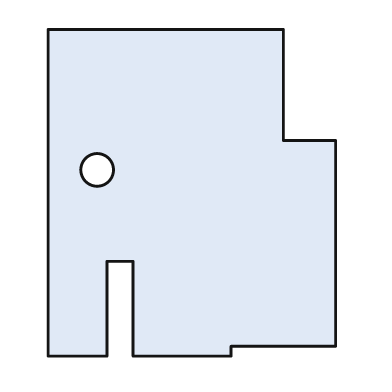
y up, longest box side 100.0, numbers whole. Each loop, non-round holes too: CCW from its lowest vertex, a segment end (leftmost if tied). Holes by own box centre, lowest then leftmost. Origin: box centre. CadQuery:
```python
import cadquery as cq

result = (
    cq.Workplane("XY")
    .moveTo(-44.0, -50.0)
    .lineTo(-26.0, -50.0)
    .lineTo(-26.0, -21.0)
    .lineTo(-18.0, -21.0)
    .lineTo(-18.0, -50.0)
    .lineTo(12.0, -50.0)
    .lineTo(12.0, -47.0)
    .lineTo(44.0, -47.0)
    .lineTo(44.0, 16.0)
    .lineTo(28.0, 16.0)
    .lineTo(28.0, 50.0)
    .lineTo(-44.0, 50.0)
    .close()
    .moveTo(-29.0, 7.0)
    .circle(5.0)
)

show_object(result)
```